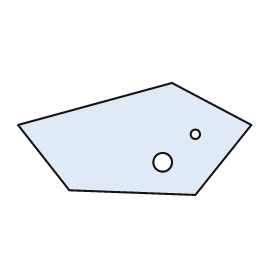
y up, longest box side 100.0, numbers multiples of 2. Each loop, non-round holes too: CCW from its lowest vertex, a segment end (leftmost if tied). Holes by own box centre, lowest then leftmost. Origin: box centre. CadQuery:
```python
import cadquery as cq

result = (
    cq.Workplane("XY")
    .moveTo(26.0, -24.0)
    .lineTo(50.0, 6.0)
    .lineTo(16.0, 24.0)
    .lineTo(-50.0, 6.0)
    .lineTo(-28.0, -22.0)
    .close()
    .moveTo(12.0, -10.0)
    .circle(4.0)
    .moveTo(26.0, 2.0)
    .circle(2.0)
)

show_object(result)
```